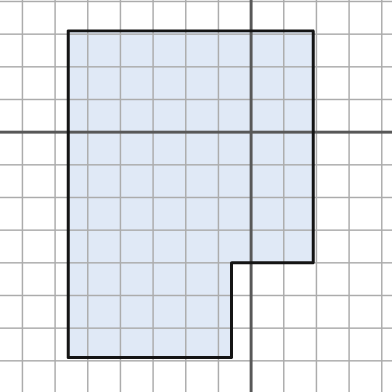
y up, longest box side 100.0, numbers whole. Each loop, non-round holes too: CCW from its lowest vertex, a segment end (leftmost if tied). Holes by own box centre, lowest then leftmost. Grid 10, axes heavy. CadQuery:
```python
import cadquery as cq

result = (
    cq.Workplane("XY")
    .moveTo(-56.0, -69.0)
    .lineTo(-6.0, -69.0)
    .lineTo(-6.0, -40.0)
    .lineTo(19.0, -40.0)
    .lineTo(19.0, 31.0)
    .lineTo(-56.0, 31.0)
    .close()
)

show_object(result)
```